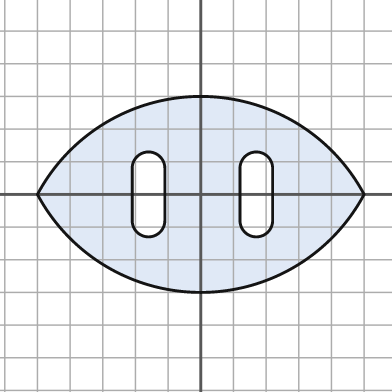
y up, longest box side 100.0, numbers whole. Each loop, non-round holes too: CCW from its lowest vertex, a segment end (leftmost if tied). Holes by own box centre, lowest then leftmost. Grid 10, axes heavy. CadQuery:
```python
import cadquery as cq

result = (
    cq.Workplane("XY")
    .moveTo(-50.0, 0.0)
    .threePointArc((0.0, -30.0), (50.0, 0.0))
    .threePointArc((0.0, 30.0), (-50.0, 0.0))
    .close()
    .moveTo(-21.0, -8.0)
    .threePointArc((-16.0, -13.0), (-11.0, -8.0))
    .lineTo(-11.0, 8.0)
    .threePointArc((-16.0, 13.0), (-21.0, 8.0))
    .close()
    .moveTo(12.0, -8.0)
    .threePointArc((17.0, -13.0), (22.0, -8.0))
    .lineTo(22.0, 8.0)
    .threePointArc((17.0, 13.0), (12.0, 8.0))
    .close()
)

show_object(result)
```